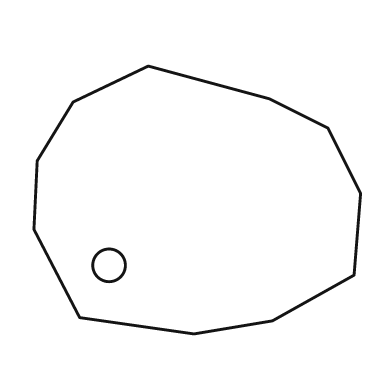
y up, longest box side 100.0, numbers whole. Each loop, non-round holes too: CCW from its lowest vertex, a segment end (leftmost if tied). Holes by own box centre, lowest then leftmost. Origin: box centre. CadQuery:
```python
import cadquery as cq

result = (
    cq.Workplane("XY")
    .moveTo(-1.0, -41.0)
    .lineTo(23.0, -37.0)
    .lineTo(48.0, -23.0)
    .lineTo(50.0, 2.0)
    .lineTo(40.0, 22.0)
    .lineTo(22.0, 31.0)
    .lineTo(-15.0, 41.0)
    .lineTo(-38.0, 30.0)
    .lineTo(-49.0, 12.0)
    .lineTo(-50.0, -9.0)
    .lineTo(-36.0, -36.0)
    .close()
    .moveTo(-27.0, -20.0)
    .circle(5.0)
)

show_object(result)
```